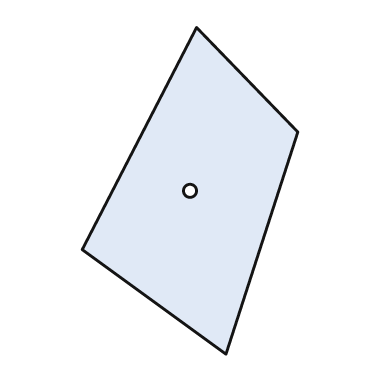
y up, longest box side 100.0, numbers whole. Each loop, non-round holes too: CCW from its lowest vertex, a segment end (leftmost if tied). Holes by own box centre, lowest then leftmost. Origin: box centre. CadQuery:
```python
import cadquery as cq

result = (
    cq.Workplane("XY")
    .moveTo(11.0, -50.0)
    .lineTo(33.0, 18.0)
    .lineTo(2.0, 50.0)
    .lineTo(-33.0, -18.0)
    .close()
    .moveTo(0.0, 0.0)
    .circle(2.0)
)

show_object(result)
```